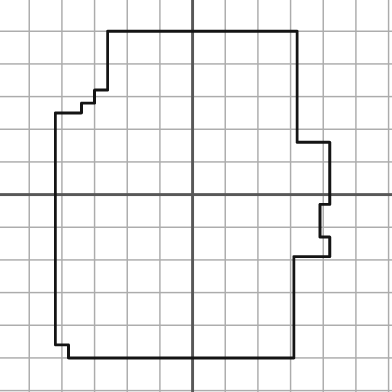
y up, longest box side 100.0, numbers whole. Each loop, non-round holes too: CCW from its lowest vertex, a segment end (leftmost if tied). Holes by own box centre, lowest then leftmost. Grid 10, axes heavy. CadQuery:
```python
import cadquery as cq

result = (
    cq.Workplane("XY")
    .moveTo(-38.0, -50.0)
    .lineTo(31.0, -50.0)
    .lineTo(31.0, -19.0)
    .lineTo(42.0, -19.0)
    .lineTo(42.0, -13.0)
    .lineTo(39.0, -13.0)
    .lineTo(39.0, -3.0)
    .lineTo(42.0, -3.0)
    .lineTo(42.0, 16.0)
    .lineTo(32.0, 16.0)
    .lineTo(32.0, 50.0)
    .lineTo(-26.0, 50.0)
    .lineTo(-26.0, 32.0)
    .lineTo(-30.0, 32.0)
    .lineTo(-30.0, 28.0)
    .lineTo(-34.0, 28.0)
    .lineTo(-34.0, 25.0)
    .lineTo(-42.0, 25.0)
    .lineTo(-42.0, -46.0)
    .lineTo(-38.0, -46.0)
    .close()
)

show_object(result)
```